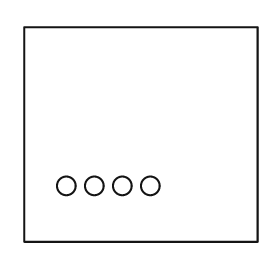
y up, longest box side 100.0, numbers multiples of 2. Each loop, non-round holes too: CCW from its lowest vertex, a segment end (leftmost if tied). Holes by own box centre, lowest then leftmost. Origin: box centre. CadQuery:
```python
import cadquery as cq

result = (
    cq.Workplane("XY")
    .moveTo(-50.0, -46.0)
    .lineTo(50.0, -46.0)
    .lineTo(50.0, 46.0)
    .lineTo(-50.0, 46.0)
    .close()
    .moveTo(-32.0, -22.0)
    .circle(4.0)
    .moveTo(-20.0, -22.0)
    .circle(4.0)
    .moveTo(-8.0, -22.0)
    .circle(4.0)
    .moveTo(4.0, -22.0)
    .circle(4.0)
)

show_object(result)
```